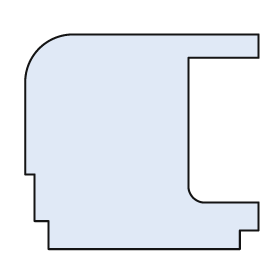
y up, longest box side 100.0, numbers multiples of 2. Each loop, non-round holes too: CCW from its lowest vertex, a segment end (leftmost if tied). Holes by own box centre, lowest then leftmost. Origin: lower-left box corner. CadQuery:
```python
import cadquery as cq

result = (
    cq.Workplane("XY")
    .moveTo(10.0, 0.0)
    .lineTo(92.0, 0.0)
    .lineTo(92.0, 8.0)
    .lineTo(100.0, 8.0)
    .lineTo(100.0, 20.0)
    .lineTo(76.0, 20.0)
    .threePointArc((72.0, 22.0), (70.0, 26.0))
    .lineTo(70.0, 82.0)
    .lineTo(100.0, 82.0)
    .lineTo(100.0, 92.0)
    .lineTo(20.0, 92.0)
    .threePointArc((6.0, 86.0), (0.0, 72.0))
    .lineTo(0.0, 32.0)
    .lineTo(4.0, 32.0)
    .lineTo(4.0, 12.0)
    .lineTo(10.0, 12.0)
    .close()
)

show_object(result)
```